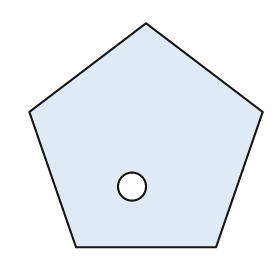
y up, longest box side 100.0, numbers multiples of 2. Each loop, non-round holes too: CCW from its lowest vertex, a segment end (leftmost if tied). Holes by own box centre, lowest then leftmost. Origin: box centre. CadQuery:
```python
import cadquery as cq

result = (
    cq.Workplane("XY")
    .moveTo(-30.0, -48.0)
    .lineTo(30.0, -48.0)
    .lineTo(50.0, 10.0)
    .lineTo(0.0, 48.0)
    .lineTo(-50.0, 10.0)
    .close()
    .moveTo(-6.0, -22.0)
    .circle(6.0)
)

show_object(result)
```